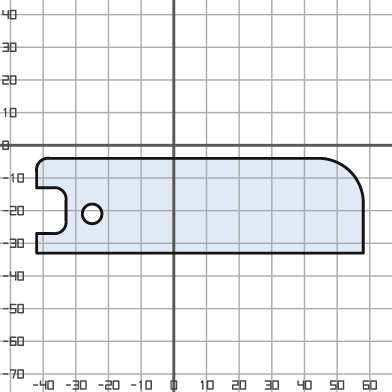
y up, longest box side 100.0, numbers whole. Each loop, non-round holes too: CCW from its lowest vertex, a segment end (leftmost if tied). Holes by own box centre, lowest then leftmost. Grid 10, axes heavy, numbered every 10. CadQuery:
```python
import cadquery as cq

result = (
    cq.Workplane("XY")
    .moveTo(-42.0, -33.0)
    .lineTo(58.0, -33.0)
    .lineTo(58.0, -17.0)
    .threePointArc((54.0, -8.0), (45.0, -4.0))
    .lineTo(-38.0, -4.0)
    .threePointArc((-41.0, -5.0), (-42.0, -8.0))
    .lineTo(-42.0, -13.0)
    .lineTo(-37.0, -13.0)
    .threePointArc((-34.0, -14.0), (-33.0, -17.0))
    .lineTo(-33.0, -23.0)
    .threePointArc((-34.0, -26.0), (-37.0, -27.0))
    .lineTo(-42.0, -27.0)
    .close()
    .moveTo(-25.0, -21.0)
    .circle(3.0)
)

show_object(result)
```